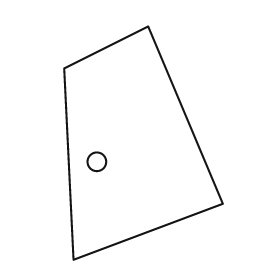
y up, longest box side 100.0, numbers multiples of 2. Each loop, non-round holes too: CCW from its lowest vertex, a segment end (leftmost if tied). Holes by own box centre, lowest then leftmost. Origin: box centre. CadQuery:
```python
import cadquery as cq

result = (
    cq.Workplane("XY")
    .moveTo(-30.0, -50.0)
    .lineTo(34.0, -26.0)
    .lineTo(2.0, 50.0)
    .lineTo(-34.0, 32.0)
    .close()
    .moveTo(-20.0, -8.0)
    .circle(4.0)
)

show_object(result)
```